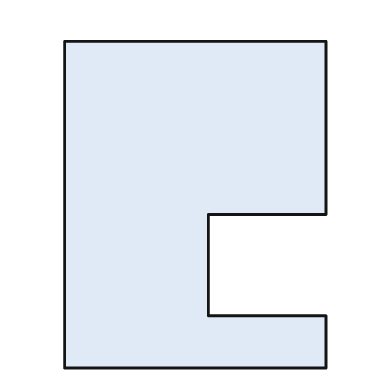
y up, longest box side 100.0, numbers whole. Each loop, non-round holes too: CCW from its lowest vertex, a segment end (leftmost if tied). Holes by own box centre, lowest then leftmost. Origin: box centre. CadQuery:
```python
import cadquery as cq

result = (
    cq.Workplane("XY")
    .moveTo(-40.0, -50.0)
    .lineTo(40.0, -50.0)
    .lineTo(40.0, -34.0)
    .lineTo(4.0, -34.0)
    .lineTo(4.0, -3.0)
    .lineTo(40.0, -3.0)
    .lineTo(40.0, 50.0)
    .lineTo(-40.0, 50.0)
    .close()
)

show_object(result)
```